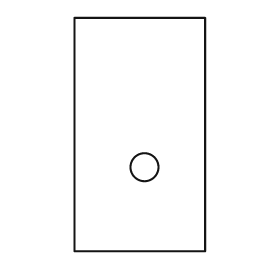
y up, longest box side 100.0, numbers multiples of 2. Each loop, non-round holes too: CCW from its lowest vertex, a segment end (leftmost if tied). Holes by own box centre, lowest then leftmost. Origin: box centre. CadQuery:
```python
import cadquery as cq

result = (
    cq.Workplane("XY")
    .moveTo(-28.0, -50.0)
    .lineTo(28.0, -50.0)
    .lineTo(28.0, 50.0)
    .lineTo(-28.0, 50.0)
    .close()
    .moveTo(2.0, -14.0)
    .circle(6.0)
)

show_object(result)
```